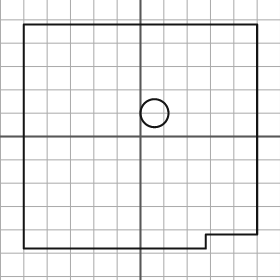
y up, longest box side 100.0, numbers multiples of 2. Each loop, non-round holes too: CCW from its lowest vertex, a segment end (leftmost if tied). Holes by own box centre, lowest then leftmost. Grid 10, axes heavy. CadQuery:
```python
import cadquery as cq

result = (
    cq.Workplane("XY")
    .moveTo(-50.0, -48.0)
    .lineTo(28.0, -48.0)
    .lineTo(28.0, -42.0)
    .lineTo(50.0, -42.0)
    .lineTo(50.0, 48.0)
    .lineTo(-50.0, 48.0)
    .close()
    .moveTo(6.0, 10.0)
    .circle(6.0)
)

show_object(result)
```